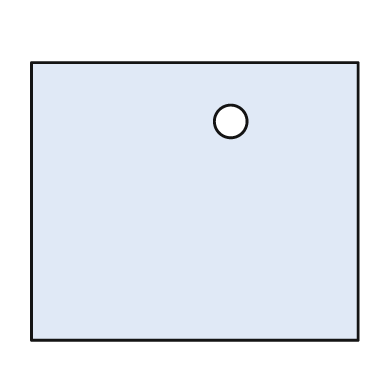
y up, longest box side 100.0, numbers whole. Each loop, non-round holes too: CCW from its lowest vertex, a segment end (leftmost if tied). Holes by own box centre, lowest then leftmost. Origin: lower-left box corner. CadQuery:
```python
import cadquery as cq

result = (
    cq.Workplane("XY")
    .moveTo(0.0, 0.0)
    .lineTo(100.0, 0.0)
    .lineTo(100.0, 85.0)
    .lineTo(0.0, 85.0)
    .close()
    .moveTo(61.0, 67.0)
    .circle(5.0)
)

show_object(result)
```